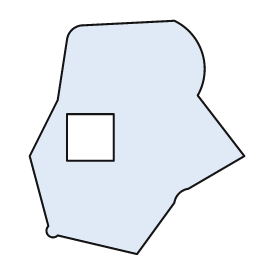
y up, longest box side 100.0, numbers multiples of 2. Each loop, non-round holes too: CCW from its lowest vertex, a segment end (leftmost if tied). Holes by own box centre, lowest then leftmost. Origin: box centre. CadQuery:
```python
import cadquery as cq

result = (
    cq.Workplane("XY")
    .moveTo(0.0, -50.0)
    .lineTo(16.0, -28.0)
    .threePointArc((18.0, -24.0), (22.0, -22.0))
    .lineTo(46.0, -8.0)
    .lineTo(26.0, 18.0)
    .threePointArc((28.0, 36.0), (16.0, 50.0))
    .lineTo(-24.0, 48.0)
    .threePointArc((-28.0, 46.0), (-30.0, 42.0))
    .lineTo(-34.0, 16.0)
    .lineTo(-46.0, -8.0)
    .lineTo(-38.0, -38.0)
    .threePointArc((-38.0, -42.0), (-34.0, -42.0))
    .close()
    .moveTo(-30.0, -10.0)
    .lineTo(-10.0, -10.0)
    .lineTo(-10.0, 10.0)
    .lineTo(-30.0, 10.0)
    .close()
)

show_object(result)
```